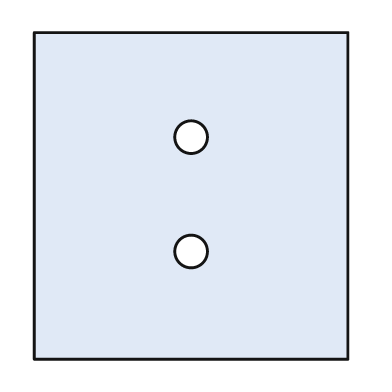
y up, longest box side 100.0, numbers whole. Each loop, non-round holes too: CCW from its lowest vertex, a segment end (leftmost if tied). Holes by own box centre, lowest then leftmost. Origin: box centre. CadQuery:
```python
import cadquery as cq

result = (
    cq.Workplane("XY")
    .moveTo(-48.0, -50.0)
    .lineTo(48.0, -50.0)
    .lineTo(48.0, 50.0)
    .lineTo(-48.0, 50.0)
    .close()
    .moveTo(0.0, -17.0)
    .circle(5.0)
    .moveTo(0.0, 18.0)
    .circle(5.0)
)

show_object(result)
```